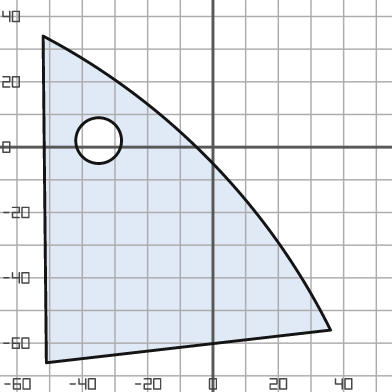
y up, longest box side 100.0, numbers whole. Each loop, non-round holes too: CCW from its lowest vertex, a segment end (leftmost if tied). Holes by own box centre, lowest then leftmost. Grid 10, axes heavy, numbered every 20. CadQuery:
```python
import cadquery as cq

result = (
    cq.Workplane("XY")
    .moveTo(-51.0, -66.0)
    .lineTo(36.0, -56.0)
    .threePointArc((-1.0, -4.0), (-52.0, 34.0))
    .close()
    .moveTo(-35.0, 2.0)
    .circle(7.0)
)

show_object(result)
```